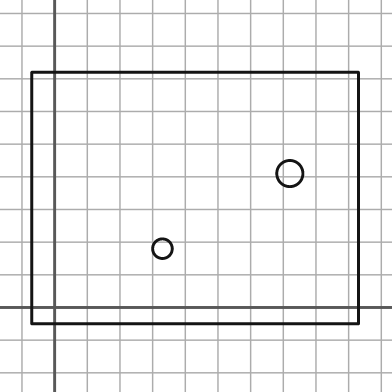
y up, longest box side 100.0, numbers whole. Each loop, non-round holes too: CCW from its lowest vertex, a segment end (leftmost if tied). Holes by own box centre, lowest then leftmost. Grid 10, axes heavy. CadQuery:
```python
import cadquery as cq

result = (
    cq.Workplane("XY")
    .moveTo(-7.0, -5.0)
    .lineTo(93.0, -5.0)
    .lineTo(93.0, 72.0)
    .lineTo(-7.0, 72.0)
    .close()
    .moveTo(33.0, 18.0)
    .circle(3.0)
    .moveTo(72.0, 41.0)
    .circle(4.0)
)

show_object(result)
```